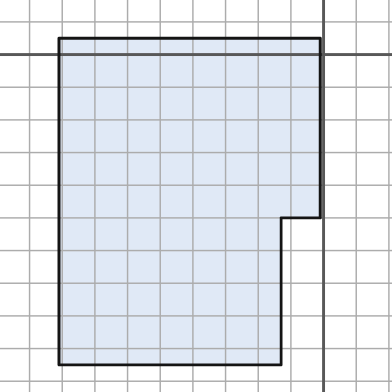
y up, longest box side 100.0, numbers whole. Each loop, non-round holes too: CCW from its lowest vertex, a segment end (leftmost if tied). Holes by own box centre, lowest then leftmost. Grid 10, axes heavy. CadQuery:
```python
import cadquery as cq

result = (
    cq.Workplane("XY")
    .moveTo(-81.0, -95.0)
    .lineTo(-13.0, -95.0)
    .lineTo(-13.0, -50.0)
    .lineTo(-1.0, -50.0)
    .lineTo(-1.0, 5.0)
    .lineTo(-81.0, 5.0)
    .close()
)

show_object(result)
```